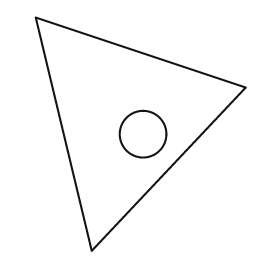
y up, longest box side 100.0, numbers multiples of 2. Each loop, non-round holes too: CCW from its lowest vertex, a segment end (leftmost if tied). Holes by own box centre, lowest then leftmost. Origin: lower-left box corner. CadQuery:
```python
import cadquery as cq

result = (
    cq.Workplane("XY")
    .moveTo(24.0, 0.0)
    .lineTo(90.0, 70.0)
    .lineTo(0.0, 100.0)
    .close()
    .moveTo(46.0, 50.0)
    .circle(10.0)
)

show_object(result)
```